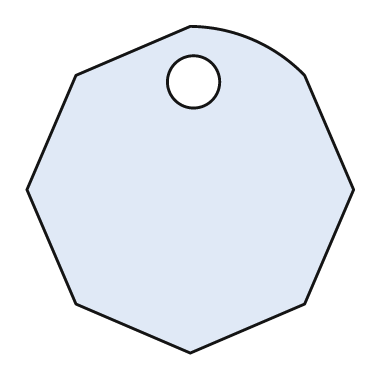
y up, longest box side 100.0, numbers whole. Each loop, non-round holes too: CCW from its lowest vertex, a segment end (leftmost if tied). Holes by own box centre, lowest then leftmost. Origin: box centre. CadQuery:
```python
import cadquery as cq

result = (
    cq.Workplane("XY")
    .moveTo(0.0, -50.0)
    .lineTo(35.0, -35.0)
    .lineTo(50.0, 0.0)
    .lineTo(35.0, 35.0)
    .threePointArc((19.0, 46.0), (0.0, 50.0))
    .lineTo(-35.0, 35.0)
    .lineTo(-50.0, 0.0)
    .lineTo(-35.0, -35.0)
    .close()
    .moveTo(1.0, 33.0)
    .circle(8.0)
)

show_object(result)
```